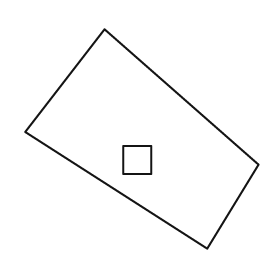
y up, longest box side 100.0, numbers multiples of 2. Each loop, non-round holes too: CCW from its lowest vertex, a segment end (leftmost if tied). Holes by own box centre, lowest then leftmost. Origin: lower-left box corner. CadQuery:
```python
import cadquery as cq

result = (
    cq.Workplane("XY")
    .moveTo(78.0, 0.0)
    .lineTo(100.0, 36.0)
    .lineTo(34.0, 94.0)
    .lineTo(0.0, 50.0)
    .close()
    .moveTo(42.0, 32.0)
    .lineTo(54.0, 32.0)
    .lineTo(54.0, 44.0)
    .lineTo(42.0, 44.0)
    .close()
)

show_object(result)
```